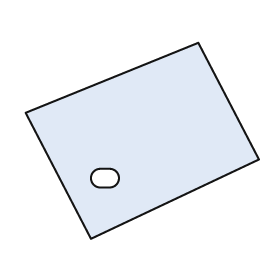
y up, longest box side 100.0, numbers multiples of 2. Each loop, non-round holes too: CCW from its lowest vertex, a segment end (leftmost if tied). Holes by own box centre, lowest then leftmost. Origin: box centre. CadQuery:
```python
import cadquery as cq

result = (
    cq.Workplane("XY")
    .moveTo(-22.0, -42.0)
    .lineTo(50.0, -8.0)
    .lineTo(24.0, 42.0)
    .lineTo(-50.0, 12.0)
    .close()
    .moveTo(-18.0, -20.0)
    .lineTo(-14.0, -20.0)
    .threePointArc((-10.0, -16.0), (-14.0, -12.0))
    .lineTo(-18.0, -12.0)
    .threePointArc((-22.0, -16.0), (-18.0, -20.0))
    .close()
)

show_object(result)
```